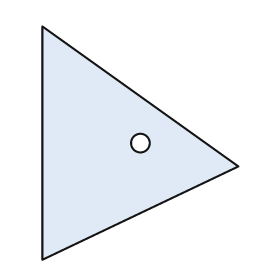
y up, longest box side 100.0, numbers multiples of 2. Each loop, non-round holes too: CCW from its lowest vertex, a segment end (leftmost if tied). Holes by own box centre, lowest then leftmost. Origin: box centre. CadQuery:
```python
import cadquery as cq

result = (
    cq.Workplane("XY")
    .moveTo(-42.0, -50.0)
    .lineTo(42.0, -10.0)
    .lineTo(-42.0, 50.0)
    .close()
    .moveTo(0.0, 0.0)
    .circle(4.0)
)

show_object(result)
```